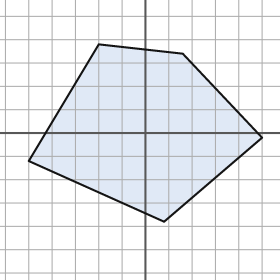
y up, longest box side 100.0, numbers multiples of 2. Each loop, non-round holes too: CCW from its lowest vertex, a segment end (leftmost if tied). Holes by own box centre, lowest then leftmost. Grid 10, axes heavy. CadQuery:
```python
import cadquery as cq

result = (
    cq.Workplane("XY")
    .moveTo(8.0, -38.0)
    .lineTo(50.0, -2.0)
    .lineTo(16.0, 34.0)
    .lineTo(-20.0, 38.0)
    .lineTo(-50.0, -12.0)
    .close()
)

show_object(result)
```